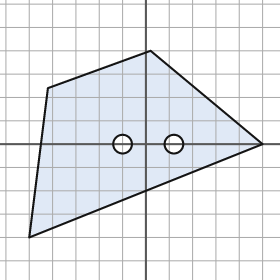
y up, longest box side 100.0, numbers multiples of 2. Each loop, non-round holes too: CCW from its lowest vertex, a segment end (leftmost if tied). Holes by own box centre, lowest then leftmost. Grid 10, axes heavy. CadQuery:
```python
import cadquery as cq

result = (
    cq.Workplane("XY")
    .moveTo(-50.0, -40.0)
    .lineTo(50.0, 0.0)
    .lineTo(2.0, 40.0)
    .lineTo(-42.0, 24.0)
    .close()
    .moveTo(-10.0, 0.0)
    .circle(4.0)
    .moveTo(12.0, 0.0)
    .circle(4.0)
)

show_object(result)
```